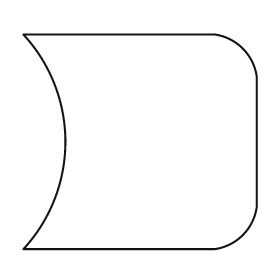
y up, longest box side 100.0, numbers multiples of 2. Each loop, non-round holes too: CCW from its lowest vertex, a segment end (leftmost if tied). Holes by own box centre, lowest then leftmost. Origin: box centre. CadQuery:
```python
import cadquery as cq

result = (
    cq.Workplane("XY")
    .moveTo(-50.0, -46.0)
    .lineTo(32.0, -46.0)
    .threePointArc((44.0, -40.0), (50.0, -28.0))
    .lineTo(50.0, 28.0)
    .threePointArc((44.0, 40.0), (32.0, 46.0))
    .lineTo(-50.0, 46.0)
    .threePointArc((-32.0, 0.0), (-50.0, -46.0))
    .close()
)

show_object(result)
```